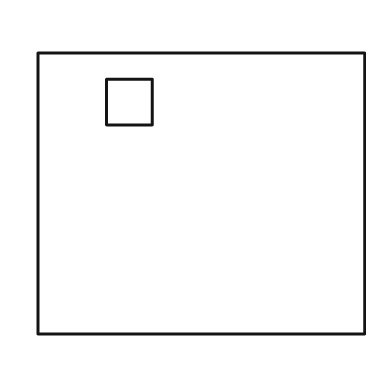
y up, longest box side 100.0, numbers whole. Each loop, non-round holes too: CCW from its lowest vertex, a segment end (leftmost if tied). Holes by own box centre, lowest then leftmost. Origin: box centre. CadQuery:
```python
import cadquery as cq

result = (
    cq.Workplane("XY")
    .moveTo(-50.0, -43.0)
    .lineTo(50.0, -43.0)
    .lineTo(50.0, 43.0)
    .lineTo(-50.0, 43.0)
    .close()
    .moveTo(-29.0, 21.0)
    .lineTo(-15.0, 21.0)
    .lineTo(-15.0, 35.0)
    .lineTo(-29.0, 35.0)
    .close()
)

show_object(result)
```